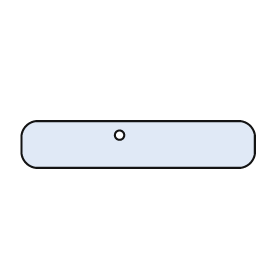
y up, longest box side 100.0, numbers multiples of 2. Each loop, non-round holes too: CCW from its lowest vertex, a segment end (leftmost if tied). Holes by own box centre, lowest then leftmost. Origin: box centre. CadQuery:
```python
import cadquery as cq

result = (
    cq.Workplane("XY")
    .moveTo(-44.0, -10.0)
    .lineTo(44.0, -10.0)
    .threePointArc((48.0, -8.0), (50.0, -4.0))
    .lineTo(50.0, 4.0)
    .threePointArc((48.0, 8.0), (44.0, 10.0))
    .lineTo(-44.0, 10.0)
    .threePointArc((-48.0, 8.0), (-50.0, 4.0))
    .lineTo(-50.0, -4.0)
    .threePointArc((-48.0, -8.0), (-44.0, -10.0))
    .close()
    .moveTo(-8.0, 4.0)
    .circle(2.0)
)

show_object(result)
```